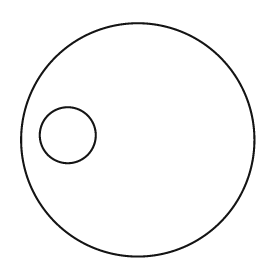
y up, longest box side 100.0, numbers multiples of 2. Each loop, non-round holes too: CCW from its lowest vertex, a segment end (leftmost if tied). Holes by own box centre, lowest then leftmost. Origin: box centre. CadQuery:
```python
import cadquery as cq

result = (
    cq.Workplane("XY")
    .moveTo(0.0, 0.0)
    .circle(50.0)
    .moveTo(-30.0, 2.0)
    .circle(12.0)
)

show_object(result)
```